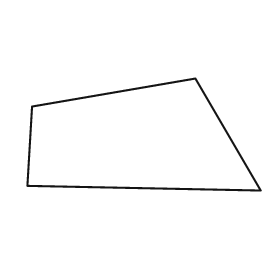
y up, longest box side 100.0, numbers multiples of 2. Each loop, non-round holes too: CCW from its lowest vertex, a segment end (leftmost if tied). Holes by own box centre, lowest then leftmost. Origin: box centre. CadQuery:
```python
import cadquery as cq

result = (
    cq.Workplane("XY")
    .moveTo(50.0, -24.0)
    .lineTo(22.0, 24.0)
    .lineTo(-48.0, 12.0)
    .lineTo(-50.0, -22.0)
    .close()
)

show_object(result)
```